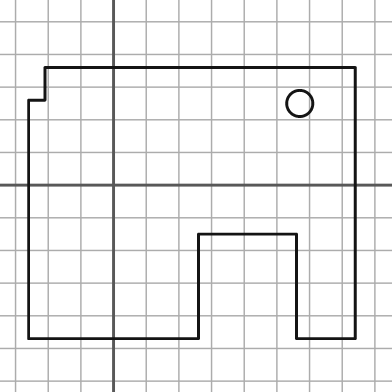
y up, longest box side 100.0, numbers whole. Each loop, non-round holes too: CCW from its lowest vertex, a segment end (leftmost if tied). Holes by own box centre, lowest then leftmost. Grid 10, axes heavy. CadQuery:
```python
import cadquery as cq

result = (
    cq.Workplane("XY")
    .moveTo(-26.0, -47.0)
    .lineTo(26.0, -47.0)
    .lineTo(26.0, -15.0)
    .lineTo(56.0, -15.0)
    .lineTo(56.0, -47.0)
    .lineTo(74.0, -47.0)
    .lineTo(74.0, 36.0)
    .lineTo(-21.0, 36.0)
    .lineTo(-21.0, 26.0)
    .lineTo(-26.0, 26.0)
    .close()
    .moveTo(57.0, 25.0)
    .circle(4.0)
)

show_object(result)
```